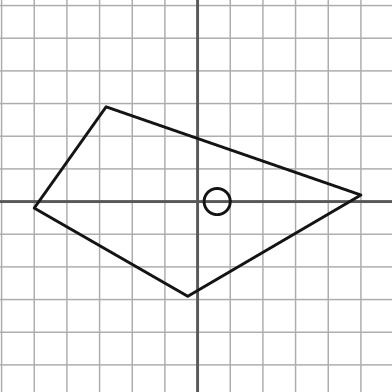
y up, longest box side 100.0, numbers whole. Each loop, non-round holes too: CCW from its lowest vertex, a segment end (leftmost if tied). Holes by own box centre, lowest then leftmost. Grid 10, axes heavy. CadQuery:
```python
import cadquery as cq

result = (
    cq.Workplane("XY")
    .moveTo(-3.0, -29.0)
    .lineTo(50.0, 2.0)
    .lineTo(-28.0, 29.0)
    .lineTo(-50.0, -2.0)
    .close()
    .moveTo(6.0, 0.0)
    .circle(4.0)
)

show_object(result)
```